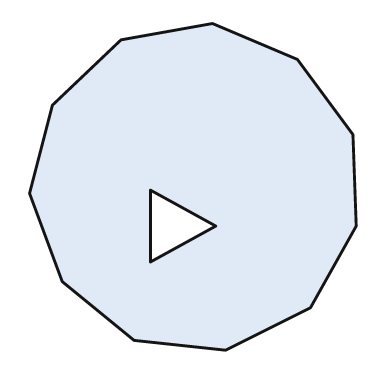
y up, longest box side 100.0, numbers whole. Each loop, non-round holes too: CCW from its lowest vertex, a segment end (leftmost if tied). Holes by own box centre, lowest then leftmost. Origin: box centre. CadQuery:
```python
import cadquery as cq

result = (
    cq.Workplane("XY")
    .moveTo(10.0, -50.0)
    .lineTo(36.0, -37.0)
    .lineTo(50.0, -12.0)
    .lineTo(49.0, 16.0)
    .lineTo(32.0, 39.0)
    .lineTo(6.0, 50.0)
    .lineTo(-22.0, 45.0)
    .lineTo(-43.0, 25.0)
    .lineTo(-50.0, -2.0)
    .lineTo(-40.0, -29.0)
    .lineTo(-18.0, -47.0)
    .close()
    .moveTo(-13.0, -23.0)
    .lineTo(7.0, -12.0)
    .lineTo(-13.0, -1.0)
    .close()
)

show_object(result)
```